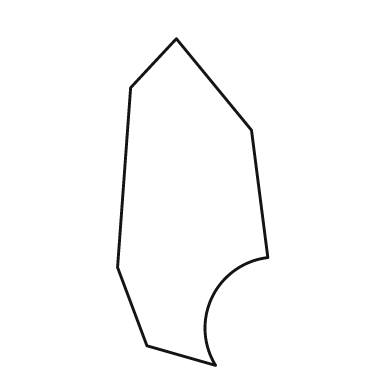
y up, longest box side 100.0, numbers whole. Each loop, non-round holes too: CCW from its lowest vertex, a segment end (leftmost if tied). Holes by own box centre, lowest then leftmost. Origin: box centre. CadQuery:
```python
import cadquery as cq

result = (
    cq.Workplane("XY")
    .moveTo(7.0, -50.0)
    .threePointArc((6.0, -29.0), (23.0, -17.0))
    .lineTo(18.0, 22.0)
    .lineTo(-5.0, 50.0)
    .lineTo(-19.0, 35.0)
    .lineTo(-23.0, -20.0)
    .lineTo(-14.0, -44.0)
    .close()
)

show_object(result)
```